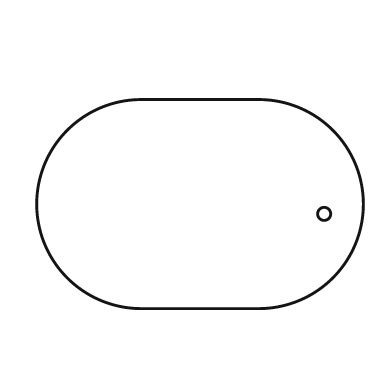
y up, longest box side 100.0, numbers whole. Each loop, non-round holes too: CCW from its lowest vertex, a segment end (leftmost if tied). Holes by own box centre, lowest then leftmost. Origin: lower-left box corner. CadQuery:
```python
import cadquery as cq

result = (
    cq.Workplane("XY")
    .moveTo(32.0, 0.0)
    .lineTo(68.0, 0.0)
    .threePointArc((100.0, 32.0), (68.0, 64.0))
    .lineTo(32.0, 64.0)
    .threePointArc((0.0, 32.0), (32.0, 0.0))
    .close()
    .moveTo(88.0, 29.0)
    .circle(2.0)
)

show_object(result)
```